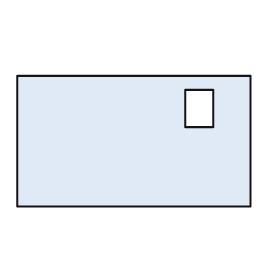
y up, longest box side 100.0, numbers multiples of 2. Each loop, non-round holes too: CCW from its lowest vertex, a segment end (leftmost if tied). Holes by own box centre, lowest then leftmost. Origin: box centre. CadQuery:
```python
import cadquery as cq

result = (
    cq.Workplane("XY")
    .moveTo(-50.0, -28.0)
    .lineTo(50.0, -28.0)
    .lineTo(50.0, 28.0)
    .lineTo(-50.0, 28.0)
    .close()
    .moveTo(22.0, 6.0)
    .lineTo(34.0, 6.0)
    .lineTo(34.0, 22.0)
    .lineTo(22.0, 22.0)
    .close()
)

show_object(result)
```